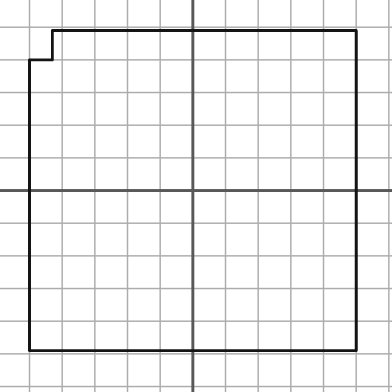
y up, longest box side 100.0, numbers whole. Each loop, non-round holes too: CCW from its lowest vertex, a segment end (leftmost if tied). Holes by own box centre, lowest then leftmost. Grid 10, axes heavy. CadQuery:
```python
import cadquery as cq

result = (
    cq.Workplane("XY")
    .moveTo(-50.0, -49.0)
    .lineTo(50.0, -49.0)
    .lineTo(50.0, 49.0)
    .lineTo(-43.0, 49.0)
    .lineTo(-43.0, 40.0)
    .lineTo(-50.0, 40.0)
    .close()
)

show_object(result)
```